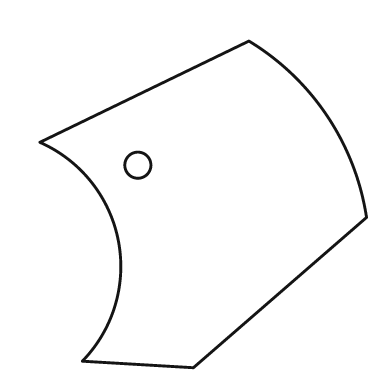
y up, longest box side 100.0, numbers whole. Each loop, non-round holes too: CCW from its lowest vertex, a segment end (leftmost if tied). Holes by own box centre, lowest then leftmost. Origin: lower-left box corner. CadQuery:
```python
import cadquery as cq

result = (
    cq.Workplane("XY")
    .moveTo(47.0, 0.0)
    .lineTo(100.0, 46.0)
    .threePointArc((88.0, 77.0), (64.0, 100.0))
    .lineTo(0.0, 69.0)
    .threePointArc((24.0, 39.0), (13.0, 2.0))
    .close()
    .moveTo(30.0, 62.0)
    .circle(4.0)
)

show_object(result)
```